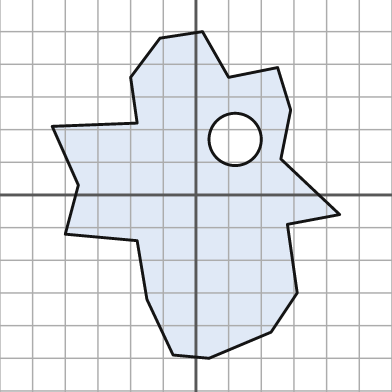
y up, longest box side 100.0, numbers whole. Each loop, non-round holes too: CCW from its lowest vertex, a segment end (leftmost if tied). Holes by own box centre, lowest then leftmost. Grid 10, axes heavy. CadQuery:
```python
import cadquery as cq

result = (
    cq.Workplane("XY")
    .moveTo(4.0, -50.0)
    .lineTo(23.0, -42.0)
    .lineTo(31.0, -30.0)
    .lineTo(28.0, -9.0)
    .lineTo(44.0, -6.0)
    .lineTo(26.0, 11.0)
    .lineTo(29.0, 26.0)
    .lineTo(25.0, 39.0)
    .lineTo(10.0, 36.0)
    .lineTo(2.0, 50.0)
    .lineTo(-11.0, 48.0)
    .lineTo(-20.0, 36.0)
    .lineTo(-18.0, 22.0)
    .lineTo(-44.0, 21.0)
    .lineTo(-36.0, 3.0)
    .lineTo(-40.0, -12.0)
    .lineTo(-18.0, -14.0)
    .lineTo(-15.0, -32.0)
    .lineTo(-7.0, -49.0)
    .close()
    .moveTo(12.0, 17.0)
    .circle(8.0)
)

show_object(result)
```